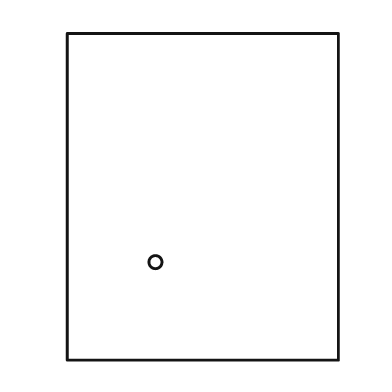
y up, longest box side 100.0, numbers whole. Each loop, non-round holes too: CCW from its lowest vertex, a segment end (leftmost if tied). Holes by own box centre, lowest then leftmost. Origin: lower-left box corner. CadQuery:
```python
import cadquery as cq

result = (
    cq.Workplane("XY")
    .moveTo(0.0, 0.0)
    .lineTo(83.0, 0.0)
    .lineTo(83.0, 100.0)
    .lineTo(0.0, 100.0)
    .close()
    .moveTo(27.0, 30.0)
    .circle(2.0)
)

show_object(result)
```